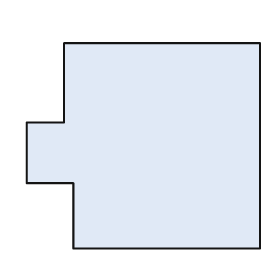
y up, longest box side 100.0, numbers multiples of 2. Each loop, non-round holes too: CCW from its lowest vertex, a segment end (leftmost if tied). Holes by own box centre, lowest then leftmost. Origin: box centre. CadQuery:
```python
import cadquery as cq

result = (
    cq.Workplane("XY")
    .moveTo(-30.0, -44.0)
    .lineTo(50.0, -44.0)
    .lineTo(50.0, 44.0)
    .lineTo(-34.0, 44.0)
    .lineTo(-34.0, 10.0)
    .lineTo(-50.0, 10.0)
    .lineTo(-50.0, -16.0)
    .lineTo(-30.0, -16.0)
    .close()
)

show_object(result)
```